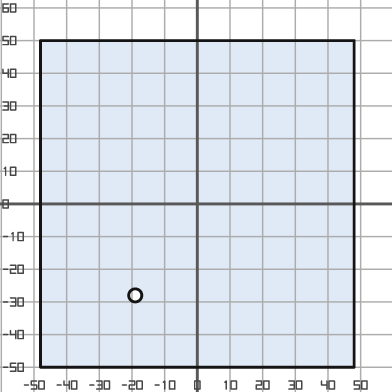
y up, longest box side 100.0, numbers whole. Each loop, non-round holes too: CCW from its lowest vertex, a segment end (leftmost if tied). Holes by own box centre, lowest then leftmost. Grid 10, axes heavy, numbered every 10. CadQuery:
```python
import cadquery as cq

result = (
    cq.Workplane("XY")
    .moveTo(-48.0, -50.0)
    .lineTo(48.0, -50.0)
    .lineTo(48.0, 50.0)
    .lineTo(-48.0, 50.0)
    .close()
    .moveTo(-19.0, -28.0)
    .circle(2.0)
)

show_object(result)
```